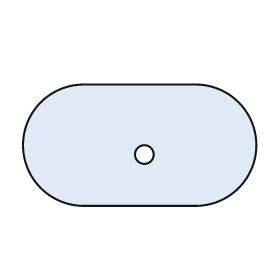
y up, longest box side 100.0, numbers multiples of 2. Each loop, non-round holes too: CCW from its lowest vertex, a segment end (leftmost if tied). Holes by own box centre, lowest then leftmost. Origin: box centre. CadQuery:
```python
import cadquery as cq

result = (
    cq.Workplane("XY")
    .moveTo(-24.0, -26.0)
    .lineTo(24.0, -26.0)
    .threePointArc((50.0, 0.0), (24.0, 26.0))
    .lineTo(-24.0, 26.0)
    .threePointArc((-50.0, 0.0), (-24.0, -26.0))
    .close()
    .moveTo(2.0, -4.0)
    .circle(4.0)
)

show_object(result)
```